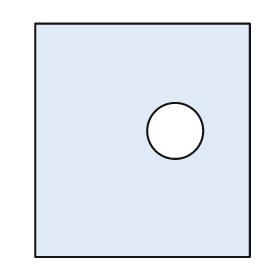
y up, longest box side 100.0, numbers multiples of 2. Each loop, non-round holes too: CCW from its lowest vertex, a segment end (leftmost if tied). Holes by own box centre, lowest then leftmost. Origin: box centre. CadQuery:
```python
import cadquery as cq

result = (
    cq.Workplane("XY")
    .moveTo(-46.0, -50.0)
    .lineTo(46.0, -50.0)
    .lineTo(46.0, 50.0)
    .lineTo(-46.0, 50.0)
    .close()
    .moveTo(14.0, 4.0)
    .circle(12.0)
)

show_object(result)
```